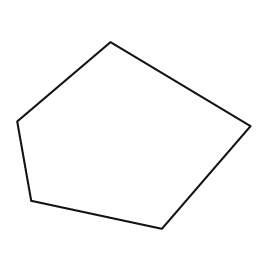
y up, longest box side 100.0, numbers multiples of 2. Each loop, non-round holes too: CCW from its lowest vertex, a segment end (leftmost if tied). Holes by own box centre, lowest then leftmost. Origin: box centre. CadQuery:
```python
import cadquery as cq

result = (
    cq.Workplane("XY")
    .moveTo(12.0, -40.0)
    .lineTo(50.0, 4.0)
    .lineTo(-10.0, 40.0)
    .lineTo(-50.0, 6.0)
    .lineTo(-44.0, -28.0)
    .close()
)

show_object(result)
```